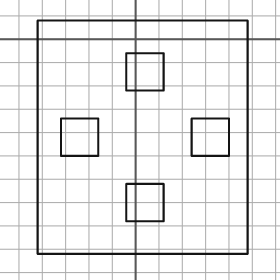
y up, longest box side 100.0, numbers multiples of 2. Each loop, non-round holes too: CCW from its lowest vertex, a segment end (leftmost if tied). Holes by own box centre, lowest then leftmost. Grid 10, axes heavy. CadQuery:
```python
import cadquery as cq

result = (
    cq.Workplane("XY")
    .moveTo(-42.0, -92.0)
    .lineTo(48.0, -92.0)
    .lineTo(48.0, 8.0)
    .lineTo(-42.0, 8.0)
    .close()
    .moveTo(-4.0, -78.0)
    .lineTo(12.0, -78.0)
    .lineTo(12.0, -62.0)
    .lineTo(-4.0, -62.0)
    .close()
    .moveTo(-32.0, -50.0)
    .lineTo(-16.0, -50.0)
    .lineTo(-16.0, -34.0)
    .lineTo(-32.0, -34.0)
    .close()
    .moveTo(24.0, -50.0)
    .lineTo(40.0, -50.0)
    .lineTo(40.0, -34.0)
    .lineTo(24.0, -34.0)
    .close()
    .moveTo(-4.0, -22.0)
    .lineTo(12.0, -22.0)
    .lineTo(12.0, -6.0)
    .lineTo(-4.0, -6.0)
    .close()
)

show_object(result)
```